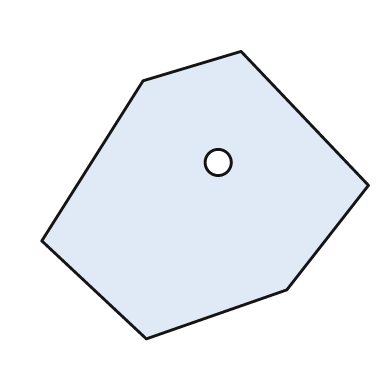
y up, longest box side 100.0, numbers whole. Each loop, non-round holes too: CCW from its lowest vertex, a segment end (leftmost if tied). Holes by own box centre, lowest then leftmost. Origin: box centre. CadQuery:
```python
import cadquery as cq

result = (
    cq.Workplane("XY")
    .moveTo(-18.0, -44.0)
    .lineTo(25.0, -29.0)
    .lineTo(50.0, 3.0)
    .lineTo(11.0, 44.0)
    .lineTo(-19.0, 35.0)
    .lineTo(-50.0, -14.0)
    .close()
    .moveTo(4.0, 10.0)
    .circle(4.0)
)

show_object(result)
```